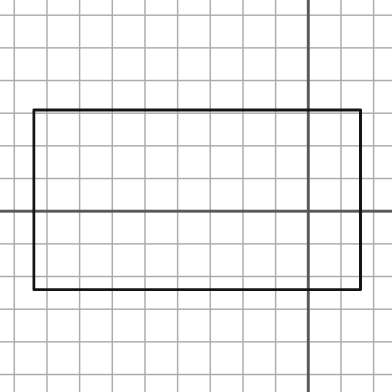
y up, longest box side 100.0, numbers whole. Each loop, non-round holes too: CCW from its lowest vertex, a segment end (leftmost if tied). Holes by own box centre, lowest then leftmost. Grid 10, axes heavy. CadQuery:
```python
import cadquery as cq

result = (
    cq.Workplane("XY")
    .moveTo(-84.0, -24.0)
    .lineTo(16.0, -24.0)
    .lineTo(16.0, 31.0)
    .lineTo(-84.0, 31.0)
    .close()
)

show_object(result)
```